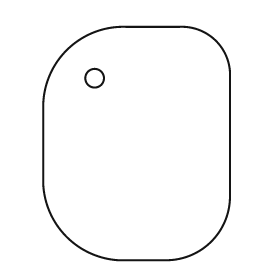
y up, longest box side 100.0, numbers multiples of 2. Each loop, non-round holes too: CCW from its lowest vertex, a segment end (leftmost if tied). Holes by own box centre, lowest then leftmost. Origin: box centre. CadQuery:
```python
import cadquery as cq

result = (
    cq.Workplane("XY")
    .moveTo(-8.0, -50.0)
    .lineTo(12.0, -50.0)
    .threePointArc((32.0, -42.0), (40.0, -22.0))
    .lineTo(40.0, 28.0)
    .threePointArc((34.0, 44.0), (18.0, 50.0))
    .lineTo(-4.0, 50.0)
    .threePointArc((-30.0, 40.0), (-40.0, 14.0))
    .lineTo(-40.0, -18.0)
    .threePointArc((-30.0, -40.0), (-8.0, -50.0))
    .close()
    .moveTo(-18.0, 28.0)
    .circle(4.0)
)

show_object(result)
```